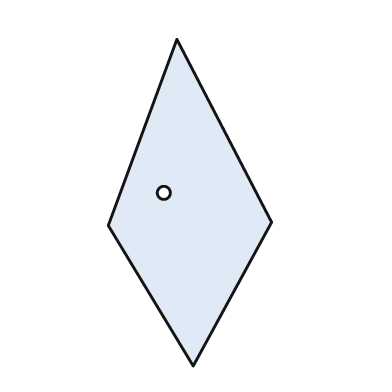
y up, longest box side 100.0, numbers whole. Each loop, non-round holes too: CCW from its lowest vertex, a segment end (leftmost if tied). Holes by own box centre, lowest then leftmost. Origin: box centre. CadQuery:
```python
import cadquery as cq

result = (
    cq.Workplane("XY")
    .moveTo(1.0, -50.0)
    .lineTo(25.0, -6.0)
    .lineTo(-4.0, 50.0)
    .lineTo(-25.0, -7.0)
    .close()
    .moveTo(-8.0, 3.0)
    .circle(2.0)
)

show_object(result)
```